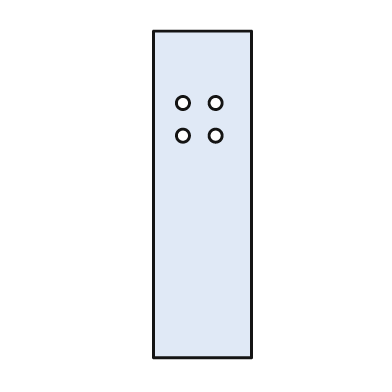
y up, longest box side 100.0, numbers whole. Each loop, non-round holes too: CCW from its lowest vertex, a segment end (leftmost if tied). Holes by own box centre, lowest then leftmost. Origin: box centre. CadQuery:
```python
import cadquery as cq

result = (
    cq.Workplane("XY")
    .moveTo(-15.0, -50.0)
    .lineTo(15.0, -50.0)
    .lineTo(15.0, 50.0)
    .lineTo(-15.0, 50.0)
    .close()
    .moveTo(-6.0, 18.0)
    .circle(2.0)
    .moveTo(4.0, 18.0)
    .circle(2.0)
    .moveTo(-6.0, 28.0)
    .circle(2.0)
    .moveTo(4.0, 28.0)
    .circle(2.0)
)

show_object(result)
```